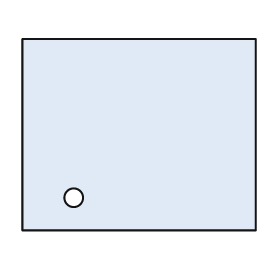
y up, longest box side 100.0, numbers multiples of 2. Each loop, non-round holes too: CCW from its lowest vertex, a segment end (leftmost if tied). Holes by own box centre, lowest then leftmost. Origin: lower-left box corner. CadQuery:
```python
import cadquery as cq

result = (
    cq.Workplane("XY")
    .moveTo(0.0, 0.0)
    .lineTo(100.0, 0.0)
    .lineTo(100.0, 82.0)
    .lineTo(0.0, 82.0)
    .close()
    .moveTo(22.0, 14.0)
    .circle(4.0)
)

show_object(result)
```